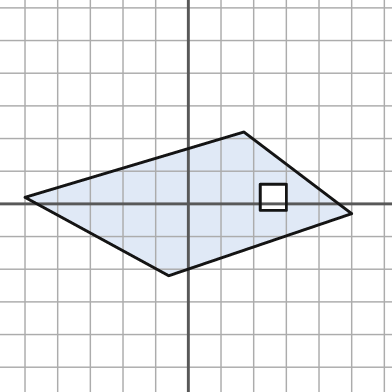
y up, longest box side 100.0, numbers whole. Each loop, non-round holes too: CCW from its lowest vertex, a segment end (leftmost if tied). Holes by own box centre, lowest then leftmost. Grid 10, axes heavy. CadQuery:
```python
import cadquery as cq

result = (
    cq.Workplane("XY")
    .moveTo(-6.0, -22.0)
    .lineTo(50.0, -3.0)
    .lineTo(17.0, 22.0)
    .lineTo(-50.0, 2.0)
    .close()
    .moveTo(22.0, -2.0)
    .lineTo(30.0, -2.0)
    .lineTo(30.0, 6.0)
    .lineTo(22.0, 6.0)
    .close()
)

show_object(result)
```